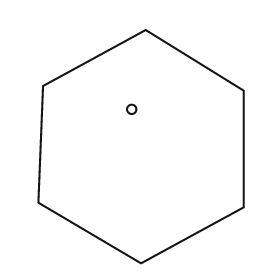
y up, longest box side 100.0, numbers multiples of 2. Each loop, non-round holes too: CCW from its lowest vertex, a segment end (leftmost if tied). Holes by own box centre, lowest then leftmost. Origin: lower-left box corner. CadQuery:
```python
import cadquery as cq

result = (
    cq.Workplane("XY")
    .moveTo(44.0, 0.0)
    .lineTo(88.0, 24.0)
    .lineTo(88.0, 74.0)
    .lineTo(46.0, 100.0)
    .lineTo(2.0, 76.0)
    .lineTo(0.0, 26.0)
    .close()
    .moveTo(40.0, 66.0)
    .circle(2.0)
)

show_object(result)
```